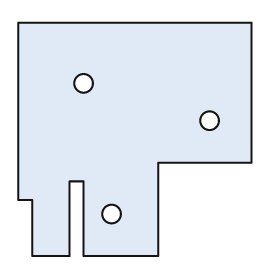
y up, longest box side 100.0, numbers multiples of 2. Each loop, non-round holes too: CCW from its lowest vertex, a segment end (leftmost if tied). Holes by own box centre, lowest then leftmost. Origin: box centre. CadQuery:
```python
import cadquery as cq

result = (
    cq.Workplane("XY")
    .moveTo(-44.0, -50.0)
    .lineTo(-28.0, -50.0)
    .lineTo(-28.0, -18.0)
    .lineTo(-22.0, -18.0)
    .lineTo(-22.0, -50.0)
    .lineTo(10.0, -50.0)
    .lineTo(10.0, -10.0)
    .lineTo(50.0, -10.0)
    .lineTo(50.0, 50.0)
    .lineTo(-50.0, 50.0)
    .lineTo(-50.0, -26.0)
    .lineTo(-44.0, -26.0)
    .close()
    .moveTo(-10.0, -32.0)
    .circle(4.0)
    .moveTo(32.0, 8.0)
    .circle(4.0)
    .moveTo(-22.0, 24.0)
    .circle(4.0)
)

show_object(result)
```